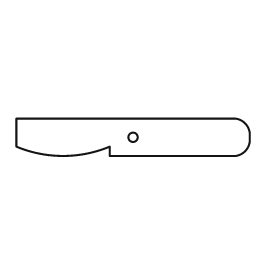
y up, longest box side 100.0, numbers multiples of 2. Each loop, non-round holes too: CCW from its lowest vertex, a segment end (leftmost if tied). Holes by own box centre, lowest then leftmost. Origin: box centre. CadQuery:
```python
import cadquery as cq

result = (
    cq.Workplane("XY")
    .moveTo(-10.0, -8.0)
    .lineTo(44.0, -8.0)
    .threePointArc((48.0, -6.0), (50.0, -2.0))
    .lineTo(50.0, 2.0)
    .threePointArc((48.0, 6.0), (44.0, 8.0))
    .lineTo(-50.0, 8.0)
    .lineTo(-50.0, -4.0)
    .threePointArc((-30.0, -8.0), (-10.0, -4.0))
    .close()
    .moveTo(0.0, 0.0)
    .circle(2.0)
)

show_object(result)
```